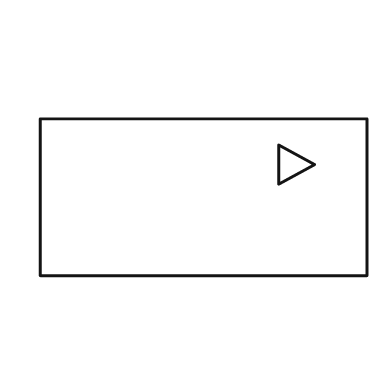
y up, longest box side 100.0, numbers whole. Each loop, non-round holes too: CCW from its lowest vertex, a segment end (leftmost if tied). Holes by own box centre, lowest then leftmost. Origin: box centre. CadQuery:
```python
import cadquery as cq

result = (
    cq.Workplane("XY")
    .moveTo(-50.0, -24.0)
    .lineTo(50.0, -24.0)
    .lineTo(50.0, 24.0)
    .lineTo(-50.0, 24.0)
    .close()
    .moveTo(23.0, 4.0)
    .lineTo(34.0, 10.0)
    .lineTo(23.0, 16.0)
    .close()
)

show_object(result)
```